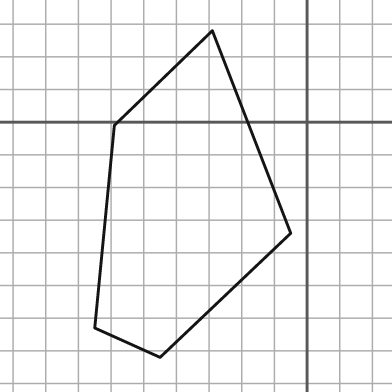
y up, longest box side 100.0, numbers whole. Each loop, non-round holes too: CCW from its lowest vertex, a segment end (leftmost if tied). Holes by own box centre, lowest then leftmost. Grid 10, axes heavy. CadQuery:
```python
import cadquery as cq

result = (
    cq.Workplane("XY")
    .moveTo(-45.0, -72.0)
    .lineTo(-5.0, -34.0)
    .lineTo(-29.0, 28.0)
    .lineTo(-59.0, -1.0)
    .lineTo(-65.0, -63.0)
    .close()
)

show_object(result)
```